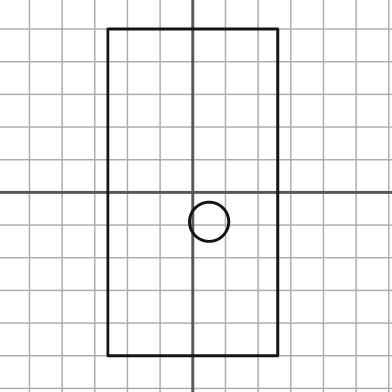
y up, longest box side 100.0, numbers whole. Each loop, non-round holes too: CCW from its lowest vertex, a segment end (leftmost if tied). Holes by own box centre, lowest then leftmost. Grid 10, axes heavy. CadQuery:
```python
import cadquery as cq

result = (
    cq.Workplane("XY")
    .moveTo(-26.0, -50.0)
    .lineTo(26.0, -50.0)
    .lineTo(26.0, 50.0)
    .lineTo(-26.0, 50.0)
    .close()
    .moveTo(5.0, -9.0)
    .circle(6.0)
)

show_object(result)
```